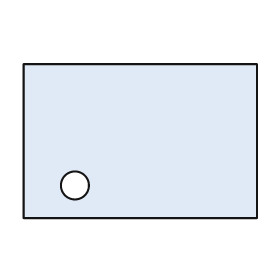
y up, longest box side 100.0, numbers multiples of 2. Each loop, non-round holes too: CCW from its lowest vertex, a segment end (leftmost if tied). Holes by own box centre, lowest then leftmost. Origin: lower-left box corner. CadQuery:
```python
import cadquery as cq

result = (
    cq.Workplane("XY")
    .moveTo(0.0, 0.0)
    .lineTo(100.0, 0.0)
    .lineTo(100.0, 66.0)
    .lineTo(0.0, 66.0)
    .close()
    .moveTo(22.0, 14.0)
    .circle(6.0)
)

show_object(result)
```